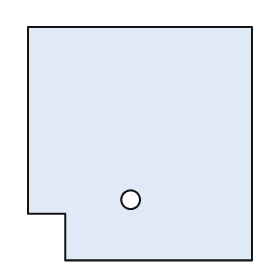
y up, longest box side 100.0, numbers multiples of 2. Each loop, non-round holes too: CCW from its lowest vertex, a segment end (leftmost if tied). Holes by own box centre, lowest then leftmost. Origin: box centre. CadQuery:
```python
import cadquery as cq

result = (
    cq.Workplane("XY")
    .moveTo(-32.0, -50.0)
    .lineTo(48.0, -50.0)
    .lineTo(48.0, 50.0)
    .lineTo(-48.0, 50.0)
    .lineTo(-48.0, -30.0)
    .lineTo(-32.0, -30.0)
    .close()
    .moveTo(-4.0, -24.0)
    .circle(4.0)
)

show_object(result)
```